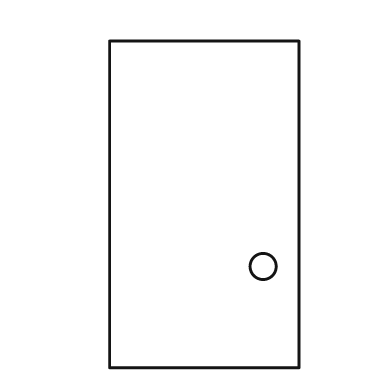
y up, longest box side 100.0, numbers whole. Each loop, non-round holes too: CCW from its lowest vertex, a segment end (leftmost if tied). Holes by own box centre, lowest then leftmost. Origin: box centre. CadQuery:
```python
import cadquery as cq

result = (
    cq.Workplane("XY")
    .moveTo(-29.0, -50.0)
    .lineTo(29.0, -50.0)
    .lineTo(29.0, 50.0)
    .lineTo(-29.0, 50.0)
    .close()
    .moveTo(18.0, -19.0)
    .circle(4.0)
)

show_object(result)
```